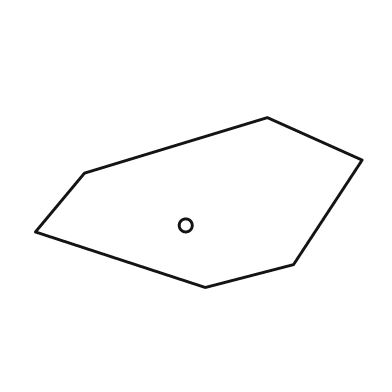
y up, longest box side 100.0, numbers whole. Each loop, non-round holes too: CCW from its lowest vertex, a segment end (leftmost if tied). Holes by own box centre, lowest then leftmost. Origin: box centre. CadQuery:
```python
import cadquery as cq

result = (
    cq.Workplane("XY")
    .moveTo(2.0, -26.0)
    .lineTo(29.0, -19.0)
    .lineTo(50.0, 13.0)
    .lineTo(21.0, 26.0)
    .lineTo(-35.0, 9.0)
    .lineTo(-50.0, -9.0)
    .close()
    .moveTo(-4.0, -7.0)
    .circle(2.0)
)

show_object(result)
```